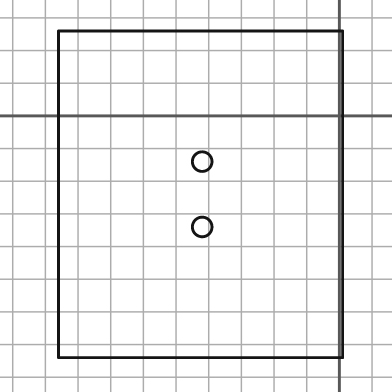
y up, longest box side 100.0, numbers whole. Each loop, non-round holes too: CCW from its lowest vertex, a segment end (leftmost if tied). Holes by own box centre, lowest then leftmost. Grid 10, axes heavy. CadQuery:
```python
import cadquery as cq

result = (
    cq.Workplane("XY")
    .moveTo(-86.0, -74.0)
    .lineTo(1.0, -74.0)
    .lineTo(1.0, 26.0)
    .lineTo(-86.0, 26.0)
    .close()
    .moveTo(-42.0, -34.0)
    .circle(3.0)
    .moveTo(-42.0, -14.0)
    .circle(3.0)
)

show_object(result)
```